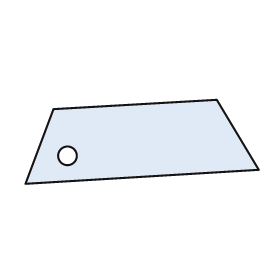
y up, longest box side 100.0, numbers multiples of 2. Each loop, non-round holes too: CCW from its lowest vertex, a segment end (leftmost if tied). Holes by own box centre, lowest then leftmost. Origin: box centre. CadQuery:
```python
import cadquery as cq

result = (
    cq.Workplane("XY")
    .moveTo(-50.0, -18.0)
    .lineTo(50.0, -12.0)
    .lineTo(32.0, 18.0)
    .lineTo(-38.0, 14.0)
    .close()
    .moveTo(-32.0, -6.0)
    .circle(4.0)
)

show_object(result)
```